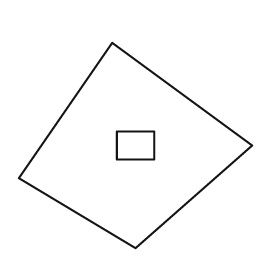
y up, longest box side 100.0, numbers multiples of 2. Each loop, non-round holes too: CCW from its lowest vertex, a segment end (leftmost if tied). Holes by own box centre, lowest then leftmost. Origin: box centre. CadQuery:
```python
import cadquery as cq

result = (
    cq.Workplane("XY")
    .moveTo(0.0, -44.0)
    .lineTo(50.0, 0.0)
    .lineTo(-10.0, 44.0)
    .lineTo(-50.0, -14.0)
    .close()
    .moveTo(-8.0, -6.0)
    .lineTo(8.0, -6.0)
    .lineTo(8.0, 6.0)
    .lineTo(-8.0, 6.0)
    .close()
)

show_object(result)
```